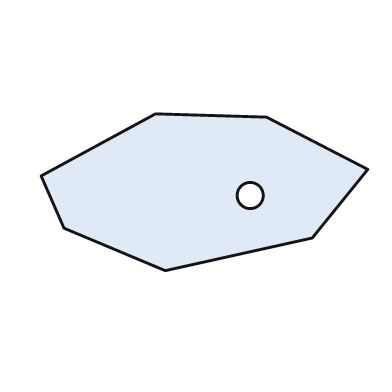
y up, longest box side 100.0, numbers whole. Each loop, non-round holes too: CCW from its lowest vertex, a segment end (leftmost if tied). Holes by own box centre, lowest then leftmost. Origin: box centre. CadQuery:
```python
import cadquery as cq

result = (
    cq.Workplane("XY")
    .moveTo(-12.0, -24.0)
    .lineTo(33.0, -14.0)
    .lineTo(50.0, 7.0)
    .lineTo(19.0, 23.0)
    .lineTo(-15.0, 24.0)
    .lineTo(-50.0, 5.0)
    .lineTo(-43.0, -11.0)
    .close()
    .moveTo(14.0, -1.0)
    .circle(4.0)
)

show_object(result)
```